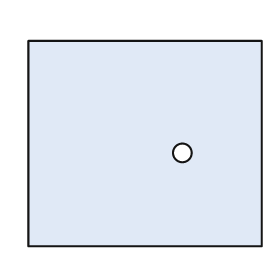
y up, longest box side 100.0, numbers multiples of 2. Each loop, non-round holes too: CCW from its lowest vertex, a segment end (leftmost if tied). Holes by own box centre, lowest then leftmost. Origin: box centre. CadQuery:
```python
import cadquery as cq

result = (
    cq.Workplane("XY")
    .moveTo(-50.0, -44.0)
    .lineTo(50.0, -44.0)
    .lineTo(50.0, 44.0)
    .lineTo(-50.0, 44.0)
    .close()
    .moveTo(16.0, -4.0)
    .circle(4.0)
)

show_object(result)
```